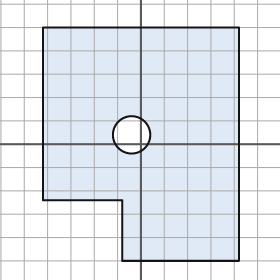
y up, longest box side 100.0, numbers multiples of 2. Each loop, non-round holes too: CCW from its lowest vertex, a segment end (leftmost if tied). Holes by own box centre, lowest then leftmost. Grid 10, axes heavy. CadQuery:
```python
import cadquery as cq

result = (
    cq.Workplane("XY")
    .moveTo(-8.0, -50.0)
    .lineTo(42.0, -50.0)
    .lineTo(42.0, 50.0)
    .lineTo(-42.0, 50.0)
    .lineTo(-42.0, -24.0)
    .lineTo(-8.0, -24.0)
    .close()
    .moveTo(-4.0, 4.0)
    .circle(8.0)
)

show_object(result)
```